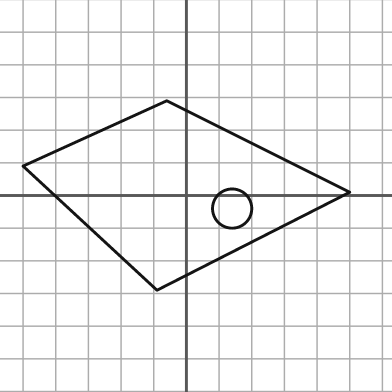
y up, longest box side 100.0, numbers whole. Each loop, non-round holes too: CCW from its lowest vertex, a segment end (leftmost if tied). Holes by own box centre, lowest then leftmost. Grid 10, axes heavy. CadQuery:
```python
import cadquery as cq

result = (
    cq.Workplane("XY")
    .moveTo(-9.0, -29.0)
    .lineTo(50.0, 1.0)
    .lineTo(-6.0, 29.0)
    .lineTo(-50.0, 9.0)
    .close()
    .moveTo(14.0, -4.0)
    .circle(6.0)
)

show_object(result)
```